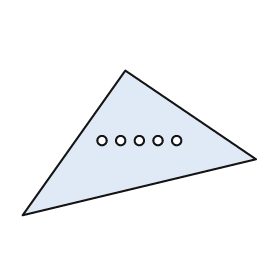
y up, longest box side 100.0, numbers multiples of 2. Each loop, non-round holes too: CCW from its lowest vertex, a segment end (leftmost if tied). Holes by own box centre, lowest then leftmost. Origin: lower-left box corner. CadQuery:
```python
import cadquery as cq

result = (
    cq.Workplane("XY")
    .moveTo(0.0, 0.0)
    .lineTo(100.0, 24.0)
    .lineTo(44.0, 62.0)
    .close()
    .moveTo(34.0, 32.0)
    .circle(2.0)
    .moveTo(42.0, 32.0)
    .circle(2.0)
    .moveTo(50.0, 32.0)
    .circle(2.0)
    .moveTo(58.0, 32.0)
    .circle(2.0)
    .moveTo(66.0, 32.0)
    .circle(2.0)
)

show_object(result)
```